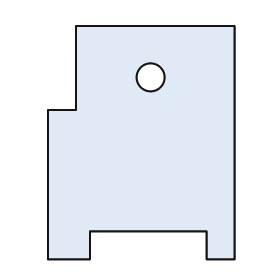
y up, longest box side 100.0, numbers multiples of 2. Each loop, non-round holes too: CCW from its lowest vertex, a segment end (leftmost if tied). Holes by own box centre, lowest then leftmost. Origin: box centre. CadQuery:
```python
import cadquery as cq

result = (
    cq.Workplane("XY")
    .moveTo(-40.0, -50.0)
    .lineTo(-22.0, -50.0)
    .lineTo(-22.0, -38.0)
    .lineTo(28.0, -38.0)
    .lineTo(28.0, -50.0)
    .lineTo(40.0, -50.0)
    .lineTo(40.0, 50.0)
    .lineTo(-28.0, 50.0)
    .lineTo(-28.0, 14.0)
    .lineTo(-40.0, 14.0)
    .close()
    .moveTo(4.0, 28.0)
    .circle(6.0)
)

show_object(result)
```